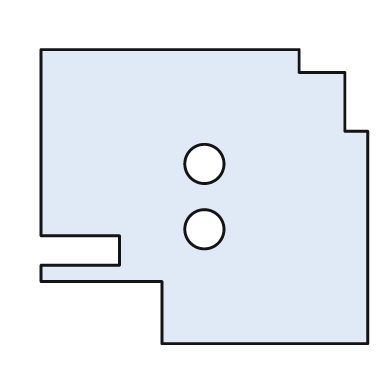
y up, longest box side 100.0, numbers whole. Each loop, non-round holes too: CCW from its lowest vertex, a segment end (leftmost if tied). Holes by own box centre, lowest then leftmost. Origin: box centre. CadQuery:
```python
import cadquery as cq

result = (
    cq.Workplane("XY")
    .moveTo(-13.0, -45.0)
    .lineTo(50.0, -45.0)
    .lineTo(50.0, 20.0)
    .lineTo(43.0, 20.0)
    .lineTo(43.0, 38.0)
    .lineTo(29.0, 38.0)
    .lineTo(29.0, 45.0)
    .lineTo(-50.0, 45.0)
    .lineTo(-50.0, -12.0)
    .lineTo(-26.0, -12.0)
    .lineTo(-26.0, -21.0)
    .lineTo(-50.0, -21.0)
    .lineTo(-50.0, -26.0)
    .lineTo(-13.0, -26.0)
    .close()
    .moveTo(0.0, -10.0)
    .circle(6.0)
    .moveTo(0.0, 10.0)
    .circle(6.0)
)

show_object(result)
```